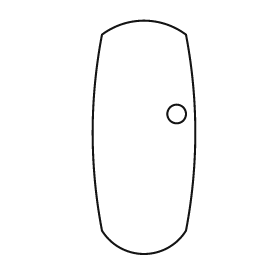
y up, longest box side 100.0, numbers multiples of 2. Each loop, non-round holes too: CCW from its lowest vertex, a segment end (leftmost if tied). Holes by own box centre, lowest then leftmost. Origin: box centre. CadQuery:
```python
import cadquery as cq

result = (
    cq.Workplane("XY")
    .moveTo(-18.0, -40.0)
    .threePointArc((0.0, -50.0), (18.0, -40.0))
    .threePointArc((22.0, 2.0), (18.0, 44.0))
    .threePointArc((0.0, 50.0), (-18.0, 44.0))
    .threePointArc((-22.0, 2.0), (-18.0, -40.0))
    .close()
    .moveTo(14.0, 10.0)
    .circle(4.0)
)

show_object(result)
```